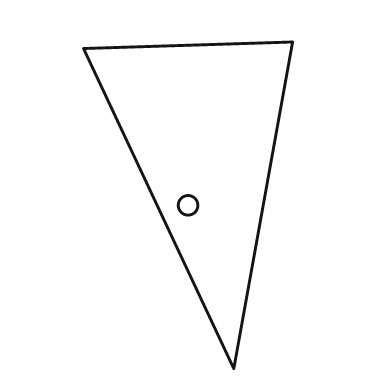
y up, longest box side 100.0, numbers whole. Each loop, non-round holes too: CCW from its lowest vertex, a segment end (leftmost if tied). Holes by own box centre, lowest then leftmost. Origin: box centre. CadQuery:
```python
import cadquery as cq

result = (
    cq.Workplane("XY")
    .moveTo(14.0, -50.0)
    .lineTo(32.0, 50.0)
    .lineTo(-32.0, 48.0)
    .close()
    .moveTo(0.0, 0.0)
    .circle(3.0)
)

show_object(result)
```